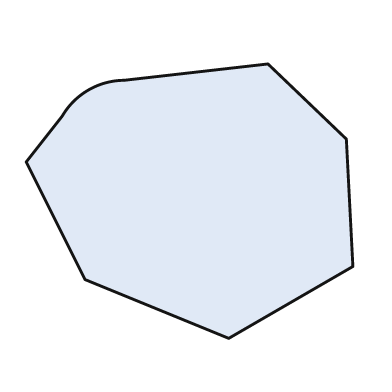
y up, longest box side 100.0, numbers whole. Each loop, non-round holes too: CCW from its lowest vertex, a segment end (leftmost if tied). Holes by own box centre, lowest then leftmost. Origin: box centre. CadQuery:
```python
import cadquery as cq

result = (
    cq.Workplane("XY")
    .moveTo(12.0, -42.0)
    .lineTo(50.0, -20.0)
    .lineTo(48.0, 19.0)
    .lineTo(24.0, 42.0)
    .lineTo(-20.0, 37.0)
    .threePointArc((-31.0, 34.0), (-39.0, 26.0))
    .lineTo(-50.0, 12.0)
    .lineTo(-32.0, -24.0)
    .close()
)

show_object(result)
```